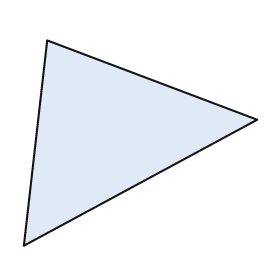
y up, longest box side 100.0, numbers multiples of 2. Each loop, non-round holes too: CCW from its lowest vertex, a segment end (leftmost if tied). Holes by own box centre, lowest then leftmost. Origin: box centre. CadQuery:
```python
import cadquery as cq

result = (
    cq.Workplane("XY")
    .moveTo(-50.0, -44.0)
    .lineTo(50.0, 10.0)
    .lineTo(-40.0, 44.0)
    .close()
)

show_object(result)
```